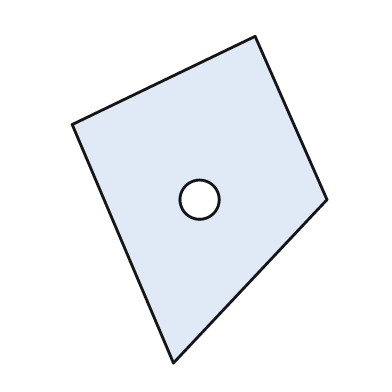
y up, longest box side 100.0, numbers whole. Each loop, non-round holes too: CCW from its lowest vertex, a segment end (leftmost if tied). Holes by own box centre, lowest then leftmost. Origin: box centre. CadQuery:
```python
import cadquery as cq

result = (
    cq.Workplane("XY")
    .moveTo(-8.0, -50.0)
    .lineTo(39.0, 0.0)
    .lineTo(17.0, 50.0)
    .lineTo(-39.0, 23.0)
    .close()
    .moveTo(0.0, 0.0)
    .circle(6.0)
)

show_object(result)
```